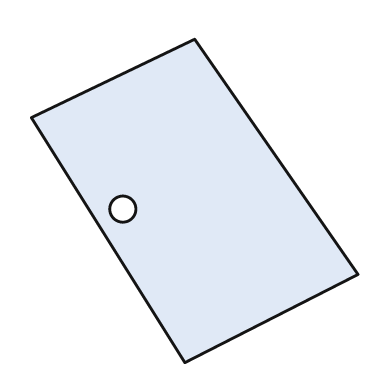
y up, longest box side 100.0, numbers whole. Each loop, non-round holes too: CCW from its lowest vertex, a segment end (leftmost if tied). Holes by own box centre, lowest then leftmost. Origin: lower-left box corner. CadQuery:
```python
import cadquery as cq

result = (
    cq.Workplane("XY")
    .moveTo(47.0, 0.0)
    .lineTo(100.0, 27.0)
    .lineTo(50.0, 99.0)
    .lineTo(0.0, 75.0)
    .close()
    .moveTo(28.0, 47.0)
    .circle(4.0)
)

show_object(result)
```